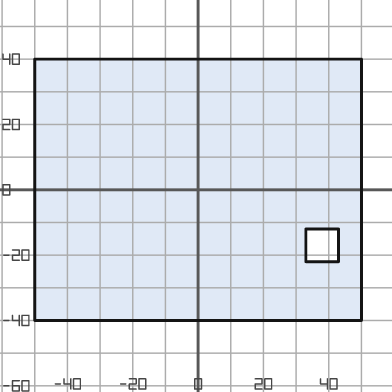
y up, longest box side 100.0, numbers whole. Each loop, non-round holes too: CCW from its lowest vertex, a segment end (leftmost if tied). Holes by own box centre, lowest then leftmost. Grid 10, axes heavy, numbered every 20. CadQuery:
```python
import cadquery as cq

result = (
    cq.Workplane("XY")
    .moveTo(-50.0, -40.0)
    .lineTo(50.0, -40.0)
    .lineTo(50.0, 40.0)
    .lineTo(-50.0, 40.0)
    .close()
    .moveTo(33.0, -22.0)
    .lineTo(43.0, -22.0)
    .lineTo(43.0, -12.0)
    .lineTo(33.0, -12.0)
    .close()
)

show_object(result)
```